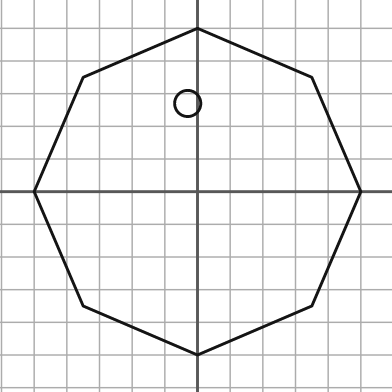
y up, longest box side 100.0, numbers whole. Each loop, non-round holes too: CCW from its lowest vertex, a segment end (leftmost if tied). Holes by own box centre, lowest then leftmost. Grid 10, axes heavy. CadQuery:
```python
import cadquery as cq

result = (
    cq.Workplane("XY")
    .moveTo(0.0, -50.0)
    .lineTo(35.0, -35.0)
    .lineTo(50.0, 0.0)
    .lineTo(35.0, 35.0)
    .lineTo(0.0, 50.0)
    .lineTo(-35.0, 35.0)
    .lineTo(-50.0, 0.0)
    .lineTo(-35.0, -35.0)
    .close()
    .moveTo(-3.0, 27.0)
    .circle(4.0)
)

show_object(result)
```